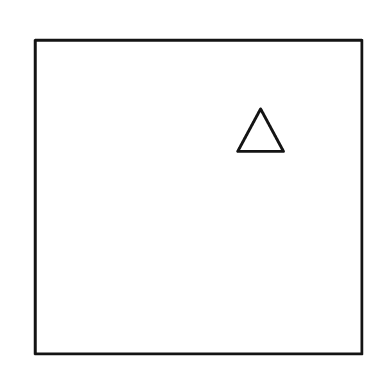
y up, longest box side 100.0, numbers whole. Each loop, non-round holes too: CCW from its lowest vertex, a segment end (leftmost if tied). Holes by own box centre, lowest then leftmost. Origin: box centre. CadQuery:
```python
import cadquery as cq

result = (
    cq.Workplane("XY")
    .moveTo(-50.0, -48.0)
    .lineTo(50.0, -48.0)
    .lineTo(50.0, 48.0)
    .lineTo(-50.0, 48.0)
    .close()
    .moveTo(12.0, 14.0)
    .lineTo(26.0, 14.0)
    .lineTo(19.0, 27.0)
    .close()
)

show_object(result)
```